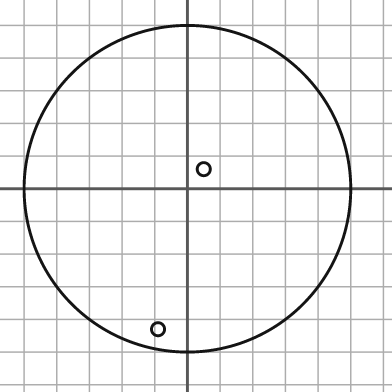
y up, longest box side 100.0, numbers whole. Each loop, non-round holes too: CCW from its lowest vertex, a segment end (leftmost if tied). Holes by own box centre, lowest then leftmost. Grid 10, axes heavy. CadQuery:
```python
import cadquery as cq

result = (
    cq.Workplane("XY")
    .moveTo(0.0, 0.0)
    .circle(50.0)
    .moveTo(-9.0, -43.0)
    .circle(2.0)
    .moveTo(5.0, 6.0)
    .circle(2.0)
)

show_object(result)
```